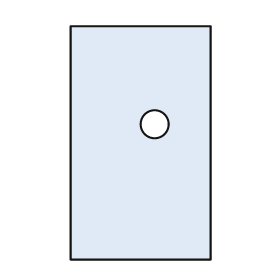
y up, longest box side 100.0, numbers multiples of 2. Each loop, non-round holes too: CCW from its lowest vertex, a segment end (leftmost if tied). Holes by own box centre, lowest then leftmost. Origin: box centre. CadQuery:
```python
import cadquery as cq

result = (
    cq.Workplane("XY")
    .moveTo(-30.0, -50.0)
    .lineTo(30.0, -50.0)
    .lineTo(30.0, 50.0)
    .lineTo(-30.0, 50.0)
    .close()
    .moveTo(6.0, 8.0)
    .circle(6.0)
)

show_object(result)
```